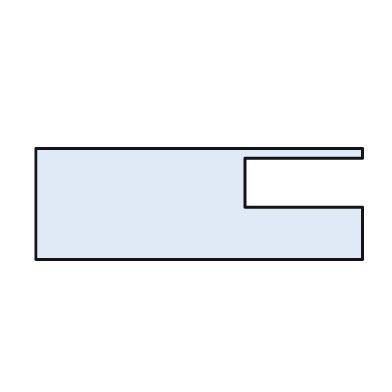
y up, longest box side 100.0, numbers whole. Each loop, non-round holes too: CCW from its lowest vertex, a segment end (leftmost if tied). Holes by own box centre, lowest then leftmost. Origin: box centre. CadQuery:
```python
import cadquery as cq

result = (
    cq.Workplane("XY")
    .moveTo(-50.0, -17.0)
    .lineTo(50.0, -17.0)
    .lineTo(50.0, -1.0)
    .lineTo(14.0, -1.0)
    .lineTo(14.0, 14.0)
    .lineTo(50.0, 14.0)
    .lineTo(50.0, 17.0)
    .lineTo(-50.0, 17.0)
    .close()
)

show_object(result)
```